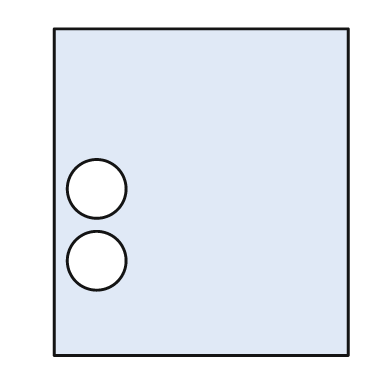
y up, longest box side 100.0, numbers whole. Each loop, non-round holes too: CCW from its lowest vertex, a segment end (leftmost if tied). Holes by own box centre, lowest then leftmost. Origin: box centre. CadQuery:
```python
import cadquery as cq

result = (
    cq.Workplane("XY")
    .moveTo(-45.0, -50.0)
    .lineTo(45.0, -50.0)
    .lineTo(45.0, 50.0)
    .lineTo(-45.0, 50.0)
    .close()
    .moveTo(-32.0, -21.0)
    .circle(9.0)
    .moveTo(-32.0, 1.0)
    .circle(9.0)
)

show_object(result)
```